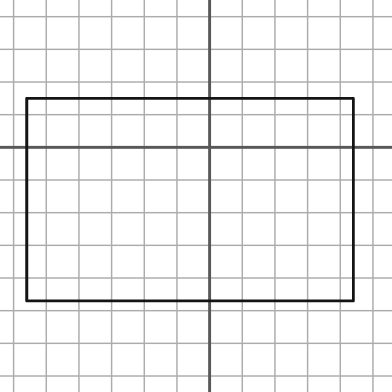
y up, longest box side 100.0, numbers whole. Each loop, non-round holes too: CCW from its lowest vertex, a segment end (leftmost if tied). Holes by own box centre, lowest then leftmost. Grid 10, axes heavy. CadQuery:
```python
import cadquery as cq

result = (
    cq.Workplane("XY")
    .moveTo(-56.0, -47.0)
    .lineTo(44.0, -47.0)
    .lineTo(44.0, 15.0)
    .lineTo(-56.0, 15.0)
    .close()
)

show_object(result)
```